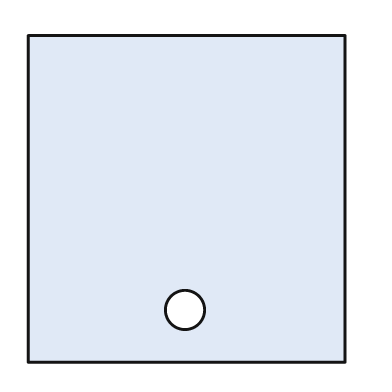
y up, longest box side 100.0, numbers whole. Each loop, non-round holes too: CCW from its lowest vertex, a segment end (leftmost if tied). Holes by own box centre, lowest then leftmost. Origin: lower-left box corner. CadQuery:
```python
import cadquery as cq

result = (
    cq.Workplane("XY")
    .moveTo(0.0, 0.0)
    .lineTo(97.0, 0.0)
    .lineTo(97.0, 100.0)
    .lineTo(0.0, 100.0)
    .close()
    .moveTo(48.0, 16.0)
    .circle(6.0)
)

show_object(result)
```